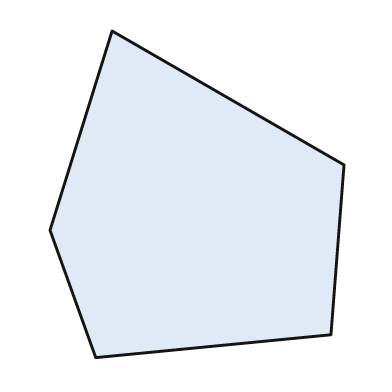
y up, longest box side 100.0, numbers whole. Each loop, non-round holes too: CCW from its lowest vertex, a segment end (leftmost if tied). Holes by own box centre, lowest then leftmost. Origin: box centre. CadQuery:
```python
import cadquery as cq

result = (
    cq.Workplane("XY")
    .moveTo(-31.0, -50.0)
    .lineTo(41.0, -43.0)
    .lineTo(45.0, 9.0)
    .lineTo(-26.0, 50.0)
    .lineTo(-45.0, -11.0)
    .close()
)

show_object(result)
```